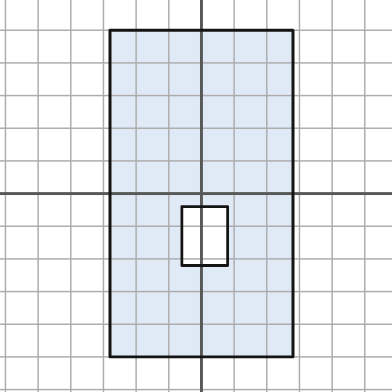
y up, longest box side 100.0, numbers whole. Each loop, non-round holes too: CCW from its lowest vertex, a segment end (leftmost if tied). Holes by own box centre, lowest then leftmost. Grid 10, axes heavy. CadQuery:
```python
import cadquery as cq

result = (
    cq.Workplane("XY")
    .moveTo(-28.0, -50.0)
    .lineTo(28.0, -50.0)
    .lineTo(28.0, 50.0)
    .lineTo(-28.0, 50.0)
    .close()
    .moveTo(-6.0, -22.0)
    .lineTo(8.0, -22.0)
    .lineTo(8.0, -4.0)
    .lineTo(-6.0, -4.0)
    .close()
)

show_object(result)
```